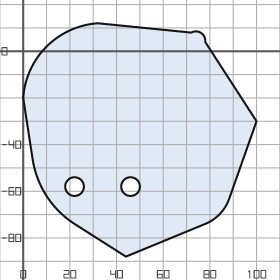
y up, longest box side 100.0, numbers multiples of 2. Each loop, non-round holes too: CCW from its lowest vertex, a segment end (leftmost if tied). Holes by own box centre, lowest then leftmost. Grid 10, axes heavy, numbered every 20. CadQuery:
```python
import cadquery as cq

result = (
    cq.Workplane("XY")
    .moveTo(44.0, -88.0)
    .lineTo(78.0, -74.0)
    .threePointArc((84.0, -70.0), (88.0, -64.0))
    .lineTo(100.0, -30.0)
    .lineTo(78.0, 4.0)
    .threePointArc((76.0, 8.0), (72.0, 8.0))
    .lineTo(32.0, 12.0)
    .threePointArc((10.0, 2.0), (0.0, -20.0))
    .lineTo(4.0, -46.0)
    .threePointArc((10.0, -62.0), (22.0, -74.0))
    .close()
    .moveTo(22.0, -58.0)
    .circle(4.0)
    .moveTo(46.0, -58.0)
    .circle(4.0)
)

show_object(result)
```